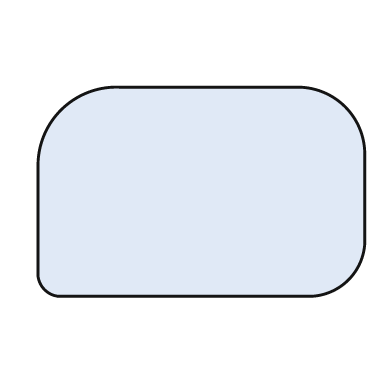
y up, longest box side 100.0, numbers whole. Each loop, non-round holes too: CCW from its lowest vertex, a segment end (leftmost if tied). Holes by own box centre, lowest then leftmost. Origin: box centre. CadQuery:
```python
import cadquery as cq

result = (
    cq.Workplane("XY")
    .moveTo(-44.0, -32.0)
    .lineTo(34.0, -32.0)
    .threePointArc((45.0, -27.0), (50.0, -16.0))
    .lineTo(50.0, 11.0)
    .threePointArc((44.0, 26.0), (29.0, 32.0))
    .lineTo(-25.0, 32.0)
    .threePointArc((-43.0, 25.0), (-50.0, 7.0))
    .lineTo(-50.0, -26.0)
    .threePointArc((-48.0, -30.0), (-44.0, -32.0))
    .close()
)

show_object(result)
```